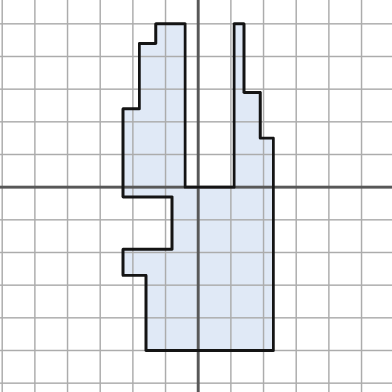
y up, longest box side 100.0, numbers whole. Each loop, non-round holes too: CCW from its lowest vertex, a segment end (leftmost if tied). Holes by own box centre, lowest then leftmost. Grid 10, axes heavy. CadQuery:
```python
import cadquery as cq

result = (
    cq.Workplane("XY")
    .moveTo(-16.0, -50.0)
    .lineTo(23.0, -50.0)
    .lineTo(23.0, 15.0)
    .lineTo(19.0, 15.0)
    .lineTo(19.0, 29.0)
    .lineTo(14.0, 29.0)
    .lineTo(14.0, 50.0)
    .lineTo(11.0, 50.0)
    .lineTo(11.0, 0.0)
    .lineTo(-4.0, 0.0)
    .lineTo(-4.0, 50.0)
    .lineTo(-13.0, 50.0)
    .lineTo(-13.0, 44.0)
    .lineTo(-18.0, 44.0)
    .lineTo(-18.0, 24.0)
    .lineTo(-23.0, 24.0)
    .lineTo(-23.0, -3.0)
    .lineTo(-8.0, -3.0)
    .lineTo(-8.0, -19.0)
    .lineTo(-23.0, -19.0)
    .lineTo(-23.0, -27.0)
    .lineTo(-16.0, -27.0)
    .close()
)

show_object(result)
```